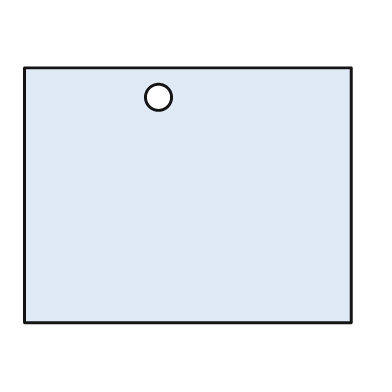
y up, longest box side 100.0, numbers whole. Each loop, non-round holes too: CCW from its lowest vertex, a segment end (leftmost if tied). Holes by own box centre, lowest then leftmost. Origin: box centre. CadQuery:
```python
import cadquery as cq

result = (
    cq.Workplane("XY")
    .moveTo(-50.0, -39.0)
    .lineTo(50.0, -39.0)
    .lineTo(50.0, 39.0)
    .lineTo(-50.0, 39.0)
    .close()
    .moveTo(-9.0, 30.0)
    .circle(4.0)
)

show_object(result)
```